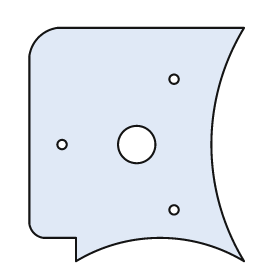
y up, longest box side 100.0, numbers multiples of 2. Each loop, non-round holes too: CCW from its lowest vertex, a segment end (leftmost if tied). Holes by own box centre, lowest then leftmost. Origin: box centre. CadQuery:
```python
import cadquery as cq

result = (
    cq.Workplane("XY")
    .moveTo(-26.0, -50.0)
    .threePointArc((10.0, -40.0), (46.0, -50.0))
    .threePointArc((32.0, 0.0), (46.0, 50.0))
    .lineTo(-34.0, 50.0)
    .threePointArc((-42.0, 46.0), (-46.0, 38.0))
    .lineTo(-46.0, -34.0)
    .threePointArc((-44.0, -38.0), (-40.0, -40.0))
    .lineTo(-26.0, -40.0)
    .close()
    .moveTo(16.0, -28.0)
    .circle(2.0)
    .moveTo(-32.0, 0.0)
    .circle(2.0)
    .moveTo(0.0, 0.0)
    .circle(8.0)
    .moveTo(16.0, 28.0)
    .circle(2.0)
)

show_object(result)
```